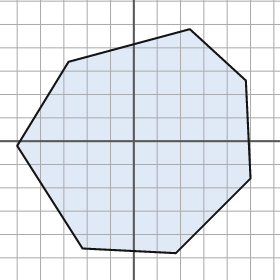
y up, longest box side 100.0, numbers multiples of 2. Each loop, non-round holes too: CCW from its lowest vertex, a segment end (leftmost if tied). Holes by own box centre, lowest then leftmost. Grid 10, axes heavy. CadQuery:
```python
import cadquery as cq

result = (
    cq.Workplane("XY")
    .moveTo(18.0, -48.0)
    .lineTo(50.0, -16.0)
    .lineTo(48.0, 26.0)
    .lineTo(24.0, 48.0)
    .lineTo(-28.0, 34.0)
    .lineTo(-50.0, -2.0)
    .lineTo(-22.0, -46.0)
    .close()
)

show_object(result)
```